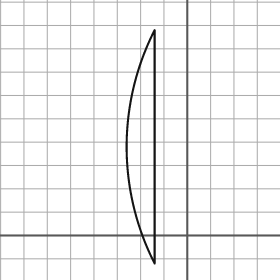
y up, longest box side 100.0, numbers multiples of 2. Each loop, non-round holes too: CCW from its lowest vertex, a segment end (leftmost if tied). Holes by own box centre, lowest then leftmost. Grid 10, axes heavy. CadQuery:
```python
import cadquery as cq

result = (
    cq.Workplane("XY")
    .moveTo(-14.0, -12.0)
    .lineTo(-14.0, 88.0)
    .threePointArc((-26.0, 38.0), (-14.0, -12.0))
    .close()
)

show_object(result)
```